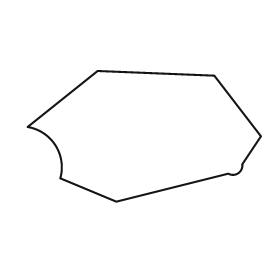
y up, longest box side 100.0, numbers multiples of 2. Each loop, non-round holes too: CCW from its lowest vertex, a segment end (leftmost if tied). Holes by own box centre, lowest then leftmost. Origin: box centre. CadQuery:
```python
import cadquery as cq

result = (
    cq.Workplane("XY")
    .moveTo(-12.0, -28.0)
    .lineTo(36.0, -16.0)
    .threePointArc((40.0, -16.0), (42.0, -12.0))
    .lineTo(50.0, 0.0)
    .lineTo(30.0, 26.0)
    .lineTo(-20.0, 28.0)
    .lineTo(-50.0, 4.0)
    .threePointArc((-38.0, -4.0), (-36.0, -18.0))
    .close()
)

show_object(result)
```